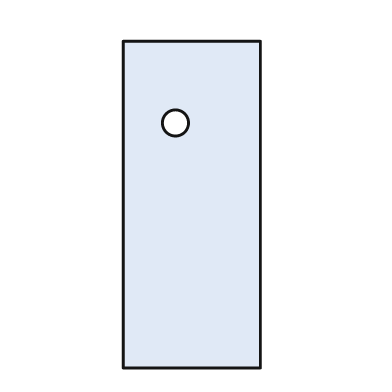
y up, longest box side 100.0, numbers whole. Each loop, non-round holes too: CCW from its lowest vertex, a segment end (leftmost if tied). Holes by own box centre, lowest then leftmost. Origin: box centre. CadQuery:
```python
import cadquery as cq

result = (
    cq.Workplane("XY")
    .moveTo(-21.0, -50.0)
    .lineTo(21.0, -50.0)
    .lineTo(21.0, 50.0)
    .lineTo(-21.0, 50.0)
    .close()
    .moveTo(-5.0, 25.0)
    .circle(4.0)
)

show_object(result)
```